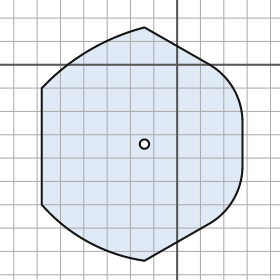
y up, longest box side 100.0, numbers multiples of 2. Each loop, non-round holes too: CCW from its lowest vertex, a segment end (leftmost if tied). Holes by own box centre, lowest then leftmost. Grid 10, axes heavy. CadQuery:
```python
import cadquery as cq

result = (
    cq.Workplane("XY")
    .moveTo(-14.0, -84.0)
    .lineTo(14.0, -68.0)
    .threePointArc((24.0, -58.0), (28.0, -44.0))
    .lineTo(28.0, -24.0)
    .threePointArc((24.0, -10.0), (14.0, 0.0))
    .lineTo(-14.0, 16.0)
    .threePointArc((-38.0, 6.0), (-58.0, -10.0))
    .lineTo(-58.0, -60.0)
    .threePointArc((-38.0, -76.0), (-14.0, -84.0))
    .close()
    .moveTo(-14.0, -34.0)
    .circle(2.0)
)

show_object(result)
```